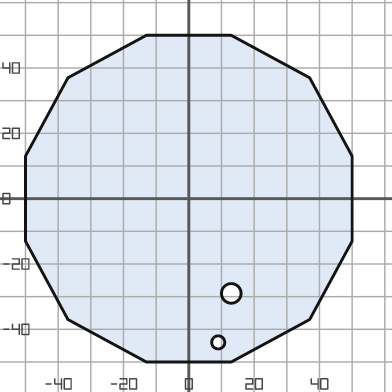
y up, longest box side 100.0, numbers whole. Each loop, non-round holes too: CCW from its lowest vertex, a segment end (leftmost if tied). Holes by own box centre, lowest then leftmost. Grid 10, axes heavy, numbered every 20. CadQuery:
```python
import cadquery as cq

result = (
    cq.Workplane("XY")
    .moveTo(-13.0, -50.0)
    .lineTo(13.0, -50.0)
    .lineTo(37.0, -37.0)
    .lineTo(50.0, -13.0)
    .lineTo(50.0, 13.0)
    .lineTo(37.0, 37.0)
    .lineTo(13.0, 50.0)
    .lineTo(-13.0, 50.0)
    .lineTo(-37.0, 37.0)
    .lineTo(-50.0, 13.0)
    .lineTo(-50.0, -13.0)
    .lineTo(-37.0, -37.0)
    .close()
    .moveTo(9.0, -44.0)
    .circle(2.0)
    .moveTo(13.0, -29.0)
    .circle(3.0)
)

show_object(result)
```